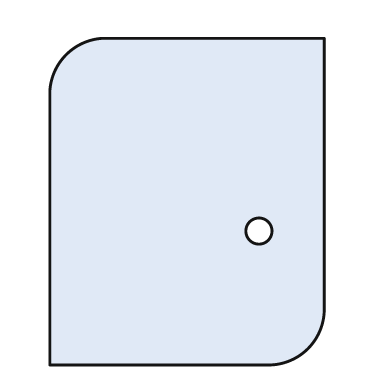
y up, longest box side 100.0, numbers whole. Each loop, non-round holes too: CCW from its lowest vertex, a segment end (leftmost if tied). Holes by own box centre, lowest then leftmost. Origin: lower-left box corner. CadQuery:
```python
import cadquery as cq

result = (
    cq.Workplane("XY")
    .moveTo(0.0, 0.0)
    .lineTo(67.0, 0.0)
    .threePointArc((79.0, 5.0), (84.0, 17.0))
    .lineTo(84.0, 100.0)
    .lineTo(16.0, 100.0)
    .threePointArc((5.0, 95.0), (0.0, 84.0))
    .close()
    .moveTo(64.0, 41.0)
    .circle(4.0)
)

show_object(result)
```